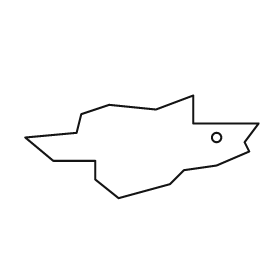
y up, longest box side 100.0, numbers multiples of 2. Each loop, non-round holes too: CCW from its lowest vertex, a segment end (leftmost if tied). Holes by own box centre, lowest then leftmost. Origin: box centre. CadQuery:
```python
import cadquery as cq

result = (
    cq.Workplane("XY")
    .moveTo(-10.0, -22.0)
    .lineTo(12.0, -16.0)
    .lineTo(18.0, -10.0)
    .lineTo(32.0, -8.0)
    .lineTo(46.0, -2.0)
    .lineTo(44.0, 2.0)
    .lineTo(50.0, 10.0)
    .lineTo(22.0, 10.0)
    .lineTo(22.0, 22.0)
    .lineTo(6.0, 16.0)
    .lineTo(-14.0, 18.0)
    .lineTo(-26.0, 14.0)
    .lineTo(-28.0, 6.0)
    .lineTo(-50.0, 4.0)
    .lineTo(-38.0, -6.0)
    .lineTo(-20.0, -6.0)
    .lineTo(-20.0, -14.0)
    .close()
    .moveTo(32.0, 4.0)
    .circle(2.0)
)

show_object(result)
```